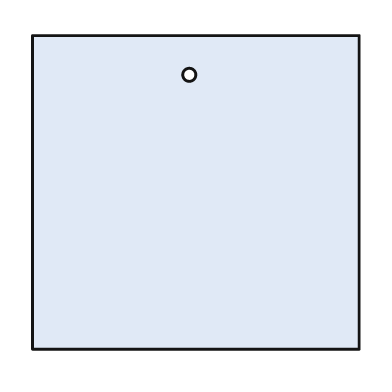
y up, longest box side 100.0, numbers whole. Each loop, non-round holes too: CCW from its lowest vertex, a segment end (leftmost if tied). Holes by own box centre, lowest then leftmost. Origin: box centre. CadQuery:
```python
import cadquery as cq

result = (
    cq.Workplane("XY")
    .moveTo(-50.0, -48.0)
    .lineTo(50.0, -48.0)
    .lineTo(50.0, 48.0)
    .lineTo(-50.0, 48.0)
    .close()
    .moveTo(-2.0, 36.0)
    .circle(2.0)
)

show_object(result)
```